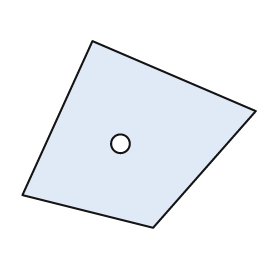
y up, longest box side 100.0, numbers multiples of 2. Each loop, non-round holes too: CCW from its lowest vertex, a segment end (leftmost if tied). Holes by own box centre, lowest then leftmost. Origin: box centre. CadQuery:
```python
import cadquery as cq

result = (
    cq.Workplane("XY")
    .moveTo(6.0, -40.0)
    .lineTo(50.0, 10.0)
    .lineTo(-20.0, 40.0)
    .lineTo(-50.0, -26.0)
    .close()
    .moveTo(-8.0, -4.0)
    .circle(4.0)
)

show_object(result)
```